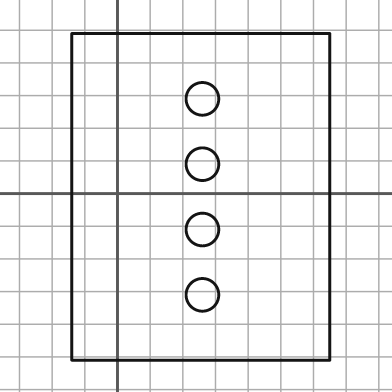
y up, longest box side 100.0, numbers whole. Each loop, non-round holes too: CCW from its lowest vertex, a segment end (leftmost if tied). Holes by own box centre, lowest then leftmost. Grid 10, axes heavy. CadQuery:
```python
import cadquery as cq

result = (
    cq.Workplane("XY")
    .moveTo(-14.0, -51.0)
    .lineTo(65.0, -51.0)
    .lineTo(65.0, 49.0)
    .lineTo(-14.0, 49.0)
    .close()
    .moveTo(26.0, -31.0)
    .circle(5.0)
    .moveTo(26.0, -11.0)
    .circle(5.0)
    .moveTo(26.0, 9.0)
    .circle(5.0)
    .moveTo(26.0, 29.0)
    .circle(5.0)
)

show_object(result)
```